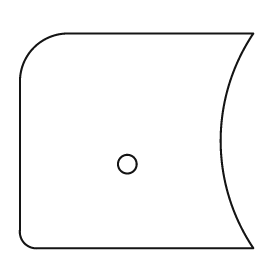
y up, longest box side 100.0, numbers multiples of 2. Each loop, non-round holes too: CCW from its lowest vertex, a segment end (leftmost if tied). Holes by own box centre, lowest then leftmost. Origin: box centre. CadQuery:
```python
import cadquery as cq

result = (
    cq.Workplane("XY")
    .moveTo(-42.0, -46.0)
    .lineTo(50.0, -46.0)
    .threePointArc((36.0, 0.0), (50.0, 46.0))
    .lineTo(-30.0, 46.0)
    .threePointArc((-44.0, 40.0), (-50.0, 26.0))
    .lineTo(-50.0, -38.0)
    .threePointArc((-48.0, -44.0), (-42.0, -46.0))
    .close()
    .moveTo(-4.0, -10.0)
    .circle(4.0)
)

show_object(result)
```